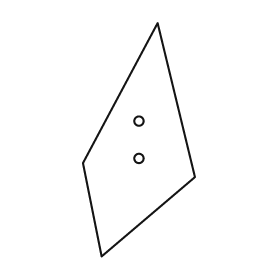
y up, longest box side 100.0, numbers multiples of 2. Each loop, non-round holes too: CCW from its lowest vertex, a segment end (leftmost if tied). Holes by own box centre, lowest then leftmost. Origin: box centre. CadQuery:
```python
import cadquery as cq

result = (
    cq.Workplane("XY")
    .moveTo(-16.0, -50.0)
    .lineTo(24.0, -16.0)
    .lineTo(8.0, 50.0)
    .lineTo(-24.0, -10.0)
    .close()
    .moveTo(0.0, -8.0)
    .circle(2.0)
    .moveTo(0.0, 8.0)
    .circle(2.0)
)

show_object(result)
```